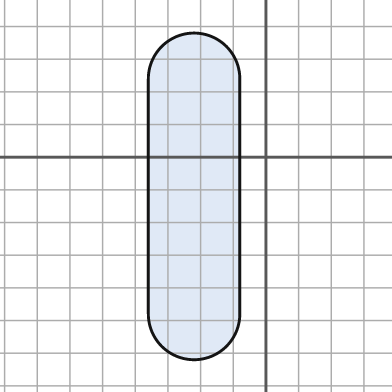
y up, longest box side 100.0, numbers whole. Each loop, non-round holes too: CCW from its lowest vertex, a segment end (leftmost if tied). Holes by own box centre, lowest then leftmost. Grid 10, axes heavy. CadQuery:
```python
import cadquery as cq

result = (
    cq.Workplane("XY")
    .moveTo(-36.0, -48.0)
    .threePointArc((-22.0, -62.0), (-8.0, -48.0))
    .lineTo(-8.0, 24.0)
    .threePointArc((-22.0, 38.0), (-36.0, 24.0))
    .close()
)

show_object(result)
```